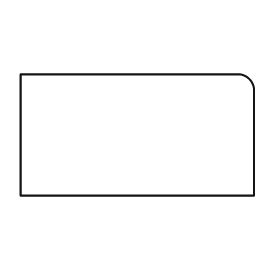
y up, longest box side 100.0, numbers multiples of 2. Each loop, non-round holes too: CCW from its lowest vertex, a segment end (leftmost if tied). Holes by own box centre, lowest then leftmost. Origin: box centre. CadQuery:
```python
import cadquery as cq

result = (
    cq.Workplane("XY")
    .moveTo(-50.0, -26.0)
    .lineTo(50.0, -26.0)
    .lineTo(50.0, 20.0)
    .threePointArc((48.0, 24.0), (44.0, 26.0))
    .lineTo(-50.0, 26.0)
    .close()
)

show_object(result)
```